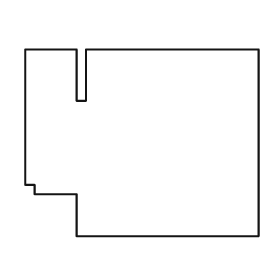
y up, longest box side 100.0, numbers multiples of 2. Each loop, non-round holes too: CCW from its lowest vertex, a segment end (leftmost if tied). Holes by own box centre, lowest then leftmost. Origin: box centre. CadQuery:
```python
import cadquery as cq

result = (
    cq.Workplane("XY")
    .moveTo(-28.0, -40.0)
    .lineTo(50.0, -40.0)
    .lineTo(50.0, 40.0)
    .lineTo(-24.0, 40.0)
    .lineTo(-24.0, 18.0)
    .lineTo(-28.0, 18.0)
    .lineTo(-28.0, 40.0)
    .lineTo(-50.0, 40.0)
    .lineTo(-50.0, -18.0)
    .lineTo(-46.0, -18.0)
    .lineTo(-46.0, -22.0)
    .lineTo(-28.0, -22.0)
    .close()
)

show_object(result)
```